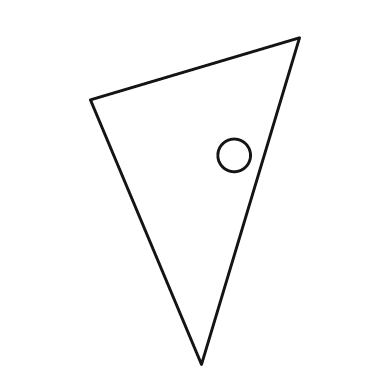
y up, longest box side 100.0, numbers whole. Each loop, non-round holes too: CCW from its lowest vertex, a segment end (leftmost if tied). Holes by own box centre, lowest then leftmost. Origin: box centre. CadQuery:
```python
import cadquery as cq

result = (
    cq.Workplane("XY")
    .moveTo(2.0, -50.0)
    .lineTo(32.0, 50.0)
    .lineTo(-32.0, 31.0)
    .close()
    .moveTo(12.0, 14.0)
    .circle(5.0)
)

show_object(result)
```